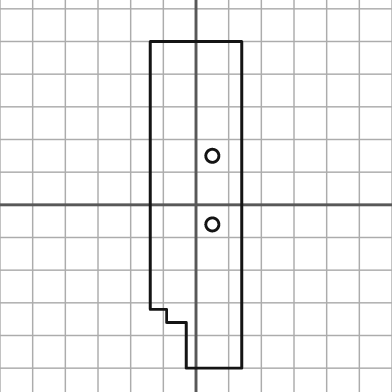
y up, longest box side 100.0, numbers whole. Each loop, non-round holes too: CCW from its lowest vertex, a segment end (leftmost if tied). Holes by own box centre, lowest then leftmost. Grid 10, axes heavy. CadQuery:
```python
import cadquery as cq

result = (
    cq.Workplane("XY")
    .moveTo(-3.0, -50.0)
    .lineTo(14.0, -50.0)
    .lineTo(14.0, 50.0)
    .lineTo(-14.0, 50.0)
    .lineTo(-14.0, -32.0)
    .lineTo(-9.0, -32.0)
    .lineTo(-9.0, -36.0)
    .lineTo(-3.0, -36.0)
    .close()
    .moveTo(5.0, -6.0)
    .circle(2.0)
    .moveTo(5.0, 15.0)
    .circle(2.0)
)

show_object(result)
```